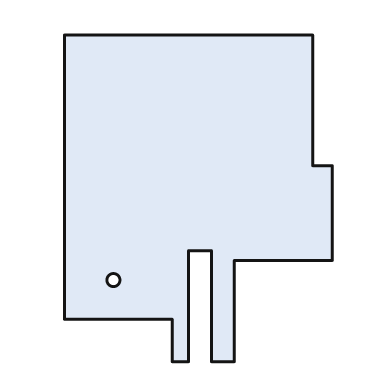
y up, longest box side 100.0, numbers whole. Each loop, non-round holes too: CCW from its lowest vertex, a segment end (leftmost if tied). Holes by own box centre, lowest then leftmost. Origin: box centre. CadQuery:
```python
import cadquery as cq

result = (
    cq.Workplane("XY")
    .moveTo(-8.0, -50.0)
    .lineTo(-3.0, -50.0)
    .lineTo(-3.0, -16.0)
    .lineTo(4.0, -16.0)
    .lineTo(4.0, -50.0)
    .lineTo(11.0, -50.0)
    .lineTo(11.0, -19.0)
    .lineTo(41.0, -19.0)
    .lineTo(41.0, 10.0)
    .lineTo(35.0, 10.0)
    .lineTo(35.0, 50.0)
    .lineTo(-41.0, 50.0)
    .lineTo(-41.0, -37.0)
    .lineTo(-8.0, -37.0)
    .close()
    .moveTo(-26.0, -25.0)
    .circle(2.0)
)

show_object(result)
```